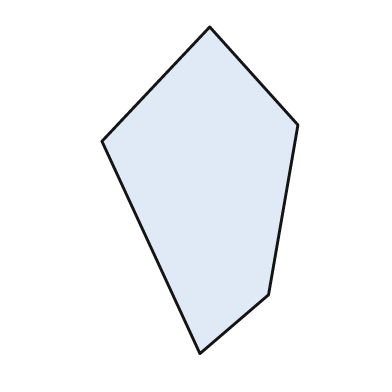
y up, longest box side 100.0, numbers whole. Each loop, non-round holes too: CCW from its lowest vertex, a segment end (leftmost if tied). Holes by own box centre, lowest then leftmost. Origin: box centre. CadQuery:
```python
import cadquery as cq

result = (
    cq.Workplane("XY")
    .moveTo(0.0, -50.0)
    .lineTo(21.0, -32.0)
    .lineTo(30.0, 20.0)
    .lineTo(3.0, 50.0)
    .lineTo(-30.0, 15.0)
    .close()
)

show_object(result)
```